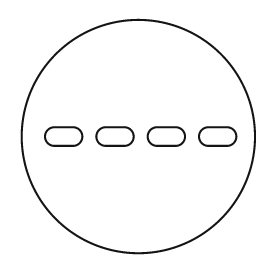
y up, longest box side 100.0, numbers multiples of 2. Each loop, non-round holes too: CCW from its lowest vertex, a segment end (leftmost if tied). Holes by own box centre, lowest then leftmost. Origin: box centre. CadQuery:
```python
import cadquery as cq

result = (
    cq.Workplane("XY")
    .moveTo(0.0, 0.0)
    .circle(50.0)
    .moveTo(-36.0, -4.0)
    .lineTo(-28.0, -4.0)
    .threePointArc((-24.0, 0.0), (-28.0, 4.0))
    .lineTo(-36.0, 4.0)
    .threePointArc((-40.0, 0.0), (-36.0, -4.0))
    .close()
    .moveTo(-14.0, -4.0)
    .lineTo(-6.0, -4.0)
    .threePointArc((-2.0, 0.0), (-6.0, 4.0))
    .lineTo(-14.0, 4.0)
    .threePointArc((-18.0, 0.0), (-14.0, -4.0))
    .close()
    .moveTo(8.0, -4.0)
    .lineTo(16.0, -4.0)
    .threePointArc((20.0, 0.0), (16.0, 4.0))
    .lineTo(8.0, 4.0)
    .threePointArc((4.0, 0.0), (8.0, -4.0))
    .close()
    .moveTo(30.0, -4.0)
    .lineTo(38.0, -4.0)
    .threePointArc((42.0, 0.0), (38.0, 4.0))
    .lineTo(30.0, 4.0)
    .threePointArc((26.0, 0.0), (30.0, -4.0))
    .close()
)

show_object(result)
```